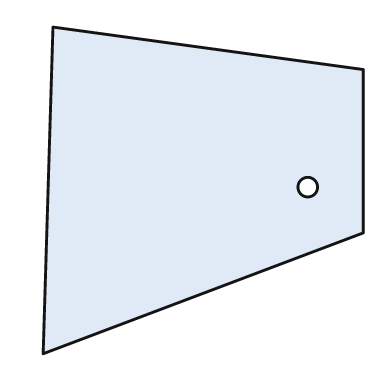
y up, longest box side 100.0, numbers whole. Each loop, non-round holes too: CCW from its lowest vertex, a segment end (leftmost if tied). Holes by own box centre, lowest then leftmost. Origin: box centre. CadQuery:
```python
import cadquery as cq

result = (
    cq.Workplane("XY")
    .moveTo(-49.0, -50.0)
    .lineTo(49.0, -13.0)
    .lineTo(49.0, 37.0)
    .lineTo(-46.0, 50.0)
    .close()
    .moveTo(32.0, 1.0)
    .circle(3.0)
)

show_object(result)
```